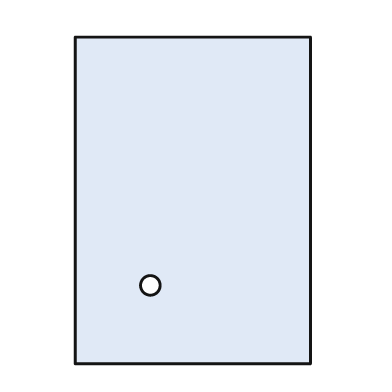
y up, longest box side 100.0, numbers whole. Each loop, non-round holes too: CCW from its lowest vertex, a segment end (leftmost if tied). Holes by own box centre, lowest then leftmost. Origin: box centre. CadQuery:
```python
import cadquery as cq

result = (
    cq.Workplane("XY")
    .moveTo(-36.0, -50.0)
    .lineTo(36.0, -50.0)
    .lineTo(36.0, 50.0)
    .lineTo(-36.0, 50.0)
    .close()
    .moveTo(-13.0, -26.0)
    .circle(3.0)
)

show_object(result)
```